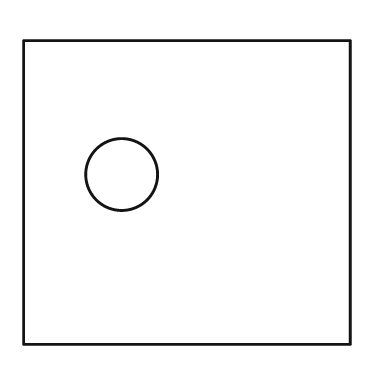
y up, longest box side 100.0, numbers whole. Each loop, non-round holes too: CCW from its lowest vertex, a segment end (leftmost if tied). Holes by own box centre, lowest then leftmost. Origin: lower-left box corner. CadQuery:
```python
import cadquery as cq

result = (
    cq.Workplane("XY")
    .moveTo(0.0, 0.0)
    .lineTo(100.0, 0.0)
    .lineTo(100.0, 93.0)
    .lineTo(0.0, 93.0)
    .close()
    .moveTo(30.0, 52.0)
    .circle(11.0)
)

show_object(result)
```